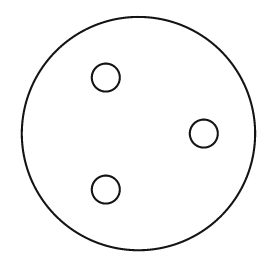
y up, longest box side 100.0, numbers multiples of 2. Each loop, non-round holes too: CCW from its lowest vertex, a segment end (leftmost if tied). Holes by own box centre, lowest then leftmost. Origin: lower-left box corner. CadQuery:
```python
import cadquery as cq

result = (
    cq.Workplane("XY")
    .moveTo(50.0, 50.0)
    .circle(50.0)
    .moveTo(36.0, 26.0)
    .circle(6.0)
    .moveTo(78.0, 50.0)
    .circle(6.0)
    .moveTo(36.0, 74.0)
    .circle(6.0)
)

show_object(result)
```